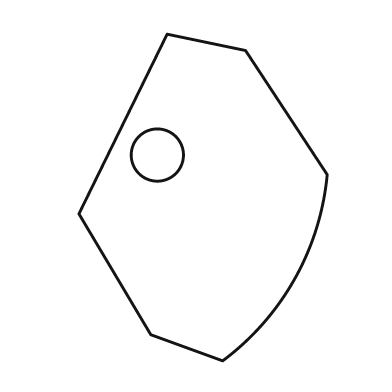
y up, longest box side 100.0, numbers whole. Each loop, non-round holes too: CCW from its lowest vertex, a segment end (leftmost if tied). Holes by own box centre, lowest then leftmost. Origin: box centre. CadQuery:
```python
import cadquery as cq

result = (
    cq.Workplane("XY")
    .moveTo(6.0, -50.0)
    .threePointArc((28.0, -25.0), (38.0, 7.0))
    .lineTo(13.0, 45.0)
    .lineTo(-11.0, 50.0)
    .lineTo(-38.0, -5.0)
    .lineTo(-16.0, -42.0)
    .close()
    .moveTo(-14.0, 13.0)
    .circle(8.0)
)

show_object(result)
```